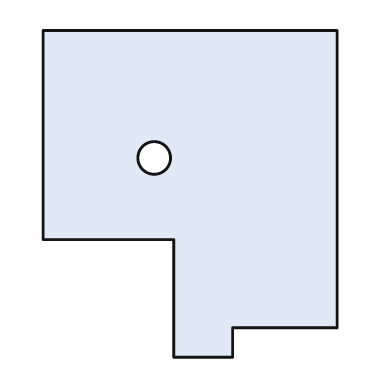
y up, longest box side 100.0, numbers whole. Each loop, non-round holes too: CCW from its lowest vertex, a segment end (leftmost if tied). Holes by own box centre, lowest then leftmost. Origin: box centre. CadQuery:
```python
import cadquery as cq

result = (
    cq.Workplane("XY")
    .moveTo(-5.0, -50.0)
    .lineTo(13.0, -50.0)
    .lineTo(13.0, -41.0)
    .lineTo(45.0, -41.0)
    .lineTo(45.0, 50.0)
    .lineTo(-45.0, 50.0)
    .lineTo(-45.0, -14.0)
    .lineTo(-5.0, -14.0)
    .close()
    .moveTo(-11.0, 11.0)
    .circle(5.0)
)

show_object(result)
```